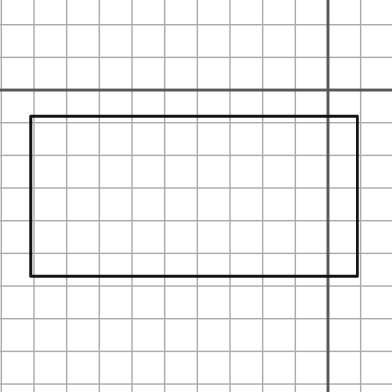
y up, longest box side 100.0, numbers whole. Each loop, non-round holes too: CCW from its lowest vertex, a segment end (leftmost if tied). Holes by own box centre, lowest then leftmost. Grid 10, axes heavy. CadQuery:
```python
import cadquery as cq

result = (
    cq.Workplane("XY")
    .moveTo(-91.0, -57.0)
    .lineTo(9.0, -57.0)
    .lineTo(9.0, -8.0)
    .lineTo(-91.0, -8.0)
    .close()
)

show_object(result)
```